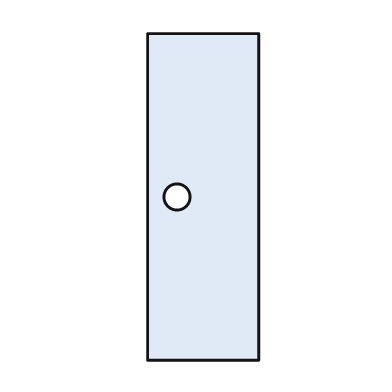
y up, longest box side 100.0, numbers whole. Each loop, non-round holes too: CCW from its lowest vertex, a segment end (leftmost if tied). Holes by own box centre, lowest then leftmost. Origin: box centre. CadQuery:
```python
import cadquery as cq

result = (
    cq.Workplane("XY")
    .moveTo(-17.0, -50.0)
    .lineTo(17.0, -50.0)
    .lineTo(17.0, 50.0)
    .lineTo(-17.0, 50.0)
    .close()
    .moveTo(-8.0, 0.0)
    .circle(4.0)
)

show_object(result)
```